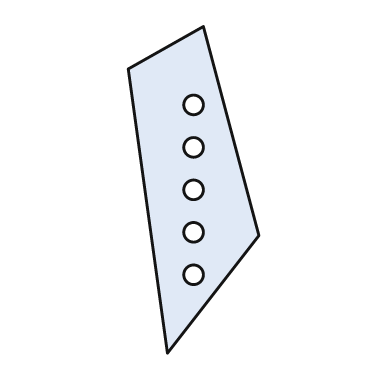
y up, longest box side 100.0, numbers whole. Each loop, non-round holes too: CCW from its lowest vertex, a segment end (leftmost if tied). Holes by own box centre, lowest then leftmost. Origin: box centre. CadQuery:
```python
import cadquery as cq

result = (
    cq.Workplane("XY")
    .moveTo(-8.0, -50.0)
    .lineTo(20.0, -14.0)
    .lineTo(3.0, 50.0)
    .lineTo(-20.0, 37.0)
    .close()
    .moveTo(0.0, -26.0)
    .circle(3.0)
    .moveTo(0.0, -13.0)
    .circle(3.0)
    .moveTo(0.0, 0.0)
    .circle(3.0)
    .moveTo(0.0, 13.0)
    .circle(3.0)
    .moveTo(0.0, 26.0)
    .circle(3.0)
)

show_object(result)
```